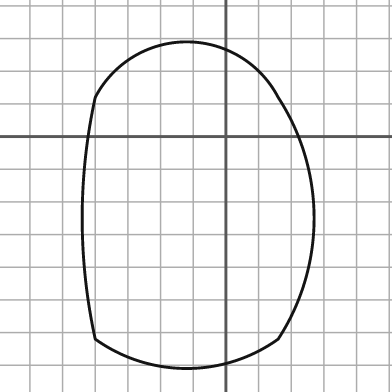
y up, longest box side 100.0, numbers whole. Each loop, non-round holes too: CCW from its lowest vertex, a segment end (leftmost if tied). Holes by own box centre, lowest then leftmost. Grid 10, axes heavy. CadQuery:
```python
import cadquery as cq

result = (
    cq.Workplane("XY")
    .moveTo(-40.0, -62.0)
    .threePointArc((-12.0, -71.0), (16.0, -62.0))
    .threePointArc((27.0, -25.0), (16.0, 12.0))
    .threePointArc((-12.0, 29.0), (-40.0, 12.0))
    .threePointArc((-44.0, -25.0), (-40.0, -62.0))
    .close()
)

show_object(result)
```